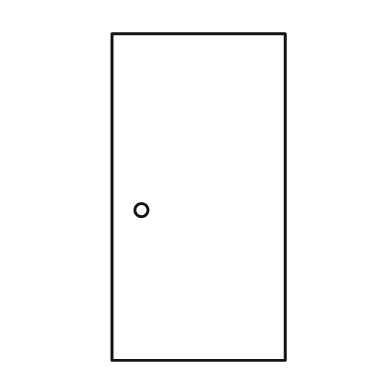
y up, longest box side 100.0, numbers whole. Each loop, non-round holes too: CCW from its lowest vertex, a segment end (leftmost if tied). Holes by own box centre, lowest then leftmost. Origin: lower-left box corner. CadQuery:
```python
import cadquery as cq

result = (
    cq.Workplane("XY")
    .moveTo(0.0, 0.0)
    .lineTo(53.0, 0.0)
    .lineTo(53.0, 100.0)
    .lineTo(0.0, 100.0)
    .close()
    .moveTo(9.0, 46.0)
    .circle(2.0)
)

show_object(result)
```